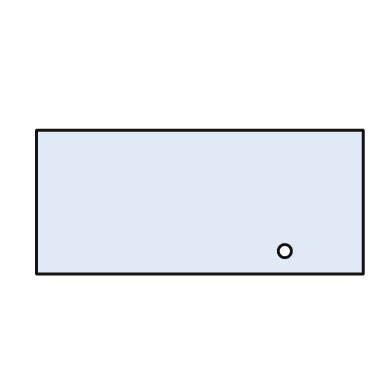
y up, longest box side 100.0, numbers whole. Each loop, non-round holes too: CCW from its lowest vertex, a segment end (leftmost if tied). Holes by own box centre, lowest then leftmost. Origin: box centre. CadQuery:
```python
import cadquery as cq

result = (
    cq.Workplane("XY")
    .moveTo(-50.0, -22.0)
    .lineTo(50.0, -22.0)
    .lineTo(50.0, 22.0)
    .lineTo(-50.0, 22.0)
    .close()
    .moveTo(26.0, -15.0)
    .circle(2.0)
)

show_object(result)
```